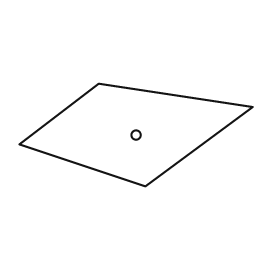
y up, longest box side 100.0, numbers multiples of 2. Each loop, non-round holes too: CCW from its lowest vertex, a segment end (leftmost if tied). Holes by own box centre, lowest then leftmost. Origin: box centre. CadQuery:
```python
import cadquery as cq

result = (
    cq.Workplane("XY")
    .moveTo(4.0, -22.0)
    .lineTo(50.0, 12.0)
    .lineTo(-16.0, 22.0)
    .lineTo(-50.0, -4.0)
    .close()
    .moveTo(0.0, 0.0)
    .circle(2.0)
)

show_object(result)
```